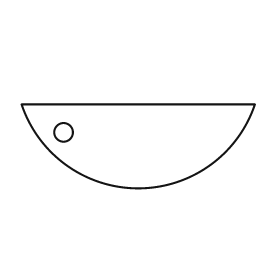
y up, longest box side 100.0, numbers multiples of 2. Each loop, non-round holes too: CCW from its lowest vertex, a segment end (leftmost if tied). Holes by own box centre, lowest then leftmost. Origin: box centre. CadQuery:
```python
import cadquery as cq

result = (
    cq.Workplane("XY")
    .moveTo(-50.0, 18.0)
    .threePointArc((0.0, -18.0), (50.0, 18.0))
    .close()
    .moveTo(-32.0, 6.0)
    .circle(4.0)
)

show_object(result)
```